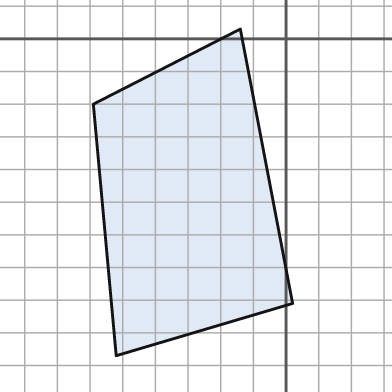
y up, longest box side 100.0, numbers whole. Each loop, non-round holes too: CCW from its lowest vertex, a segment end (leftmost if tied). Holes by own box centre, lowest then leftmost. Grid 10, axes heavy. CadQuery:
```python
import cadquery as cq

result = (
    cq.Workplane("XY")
    .moveTo(-52.0, -97.0)
    .lineTo(2.0, -81.0)
    .lineTo(-14.0, 3.0)
    .lineTo(-59.0, -20.0)
    .close()
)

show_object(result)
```